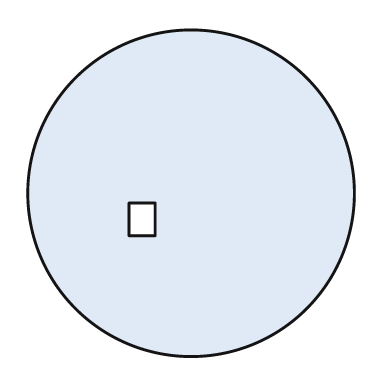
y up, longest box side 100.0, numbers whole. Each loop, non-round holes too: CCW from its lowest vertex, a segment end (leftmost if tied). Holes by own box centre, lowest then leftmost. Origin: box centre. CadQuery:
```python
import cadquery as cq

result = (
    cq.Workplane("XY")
    .moveTo(0.0, 0.0)
    .circle(50.0)
    .moveTo(-19.0, -13.0)
    .lineTo(-11.0, -13.0)
    .lineTo(-11.0, -3.0)
    .lineTo(-19.0, -3.0)
    .close()
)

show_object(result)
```